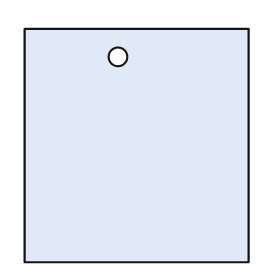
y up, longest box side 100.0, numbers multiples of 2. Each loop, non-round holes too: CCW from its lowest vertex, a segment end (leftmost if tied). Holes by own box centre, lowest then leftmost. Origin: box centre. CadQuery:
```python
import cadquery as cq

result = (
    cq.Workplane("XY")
    .moveTo(-48.0, -50.0)
    .lineTo(48.0, -50.0)
    .lineTo(48.0, 50.0)
    .lineTo(-48.0, 50.0)
    .close()
    .moveTo(-8.0, 38.0)
    .circle(4.0)
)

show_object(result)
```